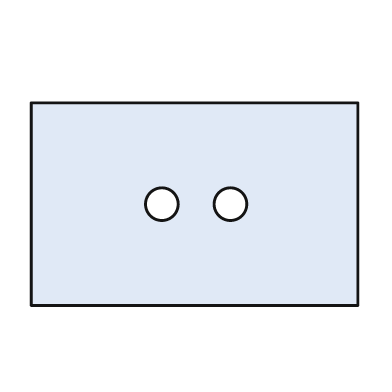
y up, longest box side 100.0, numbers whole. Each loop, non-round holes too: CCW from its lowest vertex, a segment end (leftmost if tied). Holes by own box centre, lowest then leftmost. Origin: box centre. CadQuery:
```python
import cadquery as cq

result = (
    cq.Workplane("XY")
    .moveTo(-50.0, -31.0)
    .lineTo(50.0, -31.0)
    .lineTo(50.0, 31.0)
    .lineTo(-50.0, 31.0)
    .close()
    .moveTo(-10.0, 0.0)
    .circle(5.0)
    .moveTo(11.0, 0.0)
    .circle(5.0)
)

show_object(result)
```